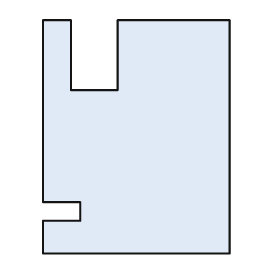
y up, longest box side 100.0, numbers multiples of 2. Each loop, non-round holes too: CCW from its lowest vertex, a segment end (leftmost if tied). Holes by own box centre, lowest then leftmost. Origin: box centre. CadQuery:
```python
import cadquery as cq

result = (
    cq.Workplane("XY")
    .moveTo(-40.0, -50.0)
    .lineTo(40.0, -50.0)
    .lineTo(40.0, 50.0)
    .lineTo(-8.0, 50.0)
    .lineTo(-8.0, 20.0)
    .lineTo(-28.0, 20.0)
    .lineTo(-28.0, 50.0)
    .lineTo(-40.0, 50.0)
    .lineTo(-40.0, -28.0)
    .lineTo(-24.0, -28.0)
    .lineTo(-24.0, -36.0)
    .lineTo(-40.0, -36.0)
    .close()
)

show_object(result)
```